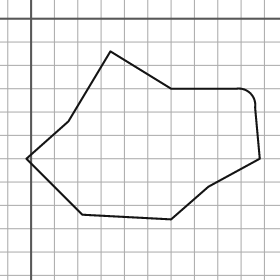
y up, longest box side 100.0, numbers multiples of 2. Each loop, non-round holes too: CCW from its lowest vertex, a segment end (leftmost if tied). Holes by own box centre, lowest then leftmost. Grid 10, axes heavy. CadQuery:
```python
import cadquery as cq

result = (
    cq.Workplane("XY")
    .moveTo(60.0, -86.0)
    .lineTo(76.0, -72.0)
    .lineTo(98.0, -60.0)
    .lineTo(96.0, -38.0)
    .threePointArc((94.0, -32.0), (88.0, -30.0))
    .lineTo(60.0, -30.0)
    .lineTo(34.0, -14.0)
    .lineTo(16.0, -44.0)
    .lineTo(-2.0, -60.0)
    .lineTo(22.0, -84.0)
    .close()
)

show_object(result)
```